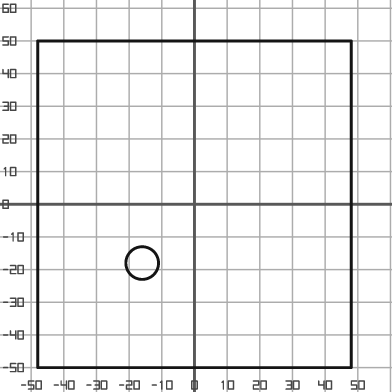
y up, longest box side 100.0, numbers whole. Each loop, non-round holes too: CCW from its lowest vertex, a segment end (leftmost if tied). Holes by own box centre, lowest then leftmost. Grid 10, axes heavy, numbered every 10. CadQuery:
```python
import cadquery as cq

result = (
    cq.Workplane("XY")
    .moveTo(-48.0, -50.0)
    .lineTo(48.0, -50.0)
    .lineTo(48.0, 50.0)
    .lineTo(-48.0, 50.0)
    .close()
    .moveTo(-16.0, -18.0)
    .circle(5.0)
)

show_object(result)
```